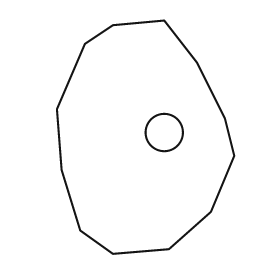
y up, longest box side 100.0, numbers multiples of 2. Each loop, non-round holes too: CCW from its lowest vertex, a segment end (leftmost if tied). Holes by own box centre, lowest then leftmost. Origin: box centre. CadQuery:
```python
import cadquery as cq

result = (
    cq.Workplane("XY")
    .moveTo(-14.0, -50.0)
    .lineTo(10.0, -48.0)
    .lineTo(28.0, -32.0)
    .lineTo(38.0, -8.0)
    .lineTo(34.0, 8.0)
    .lineTo(22.0, 32.0)
    .lineTo(8.0, 50.0)
    .lineTo(-14.0, 48.0)
    .lineTo(-26.0, 40.0)
    .lineTo(-38.0, 12.0)
    .lineTo(-36.0, -14.0)
    .lineTo(-28.0, -40.0)
    .close()
    .moveTo(8.0, 2.0)
    .circle(8.0)
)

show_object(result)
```